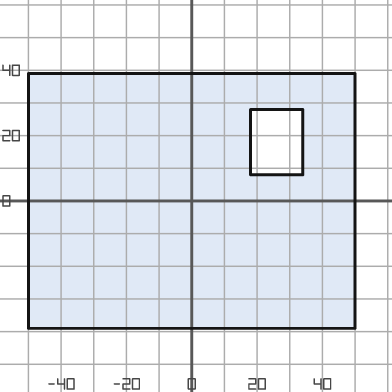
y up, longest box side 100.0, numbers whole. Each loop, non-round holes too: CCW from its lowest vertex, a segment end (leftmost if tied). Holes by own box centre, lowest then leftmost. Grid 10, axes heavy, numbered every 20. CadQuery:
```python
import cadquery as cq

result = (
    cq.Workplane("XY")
    .moveTo(-50.0, -39.0)
    .lineTo(50.0, -39.0)
    .lineTo(50.0, 39.0)
    .lineTo(-50.0, 39.0)
    .close()
    .moveTo(18.0, 8.0)
    .lineTo(34.0, 8.0)
    .lineTo(34.0, 28.0)
    .lineTo(18.0, 28.0)
    .close()
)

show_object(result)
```